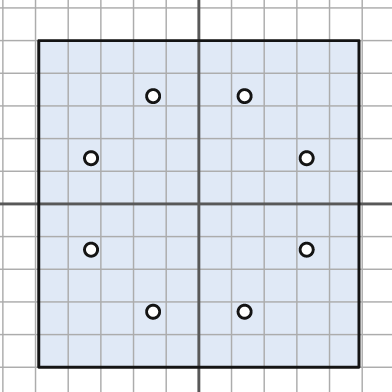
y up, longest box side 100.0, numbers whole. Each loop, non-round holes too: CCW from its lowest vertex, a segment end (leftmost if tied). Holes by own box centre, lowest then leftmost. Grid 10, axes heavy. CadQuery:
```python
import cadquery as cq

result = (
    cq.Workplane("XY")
    .moveTo(-49.0, -50.0)
    .lineTo(49.0, -50.0)
    .lineTo(49.0, 50.0)
    .lineTo(-49.0, 50.0)
    .close()
    .moveTo(-14.0, -33.0)
    .circle(2.0)
    .moveTo(14.0, -33.0)
    .circle(2.0)
    .moveTo(-33.0, -14.0)
    .circle(2.0)
    .moveTo(33.0, -14.0)
    .circle(2.0)
    .moveTo(-33.0, 14.0)
    .circle(2.0)
    .moveTo(33.0, 14.0)
    .circle(2.0)
    .moveTo(-14.0, 33.0)
    .circle(2.0)
    .moveTo(14.0, 33.0)
    .circle(2.0)
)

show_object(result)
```